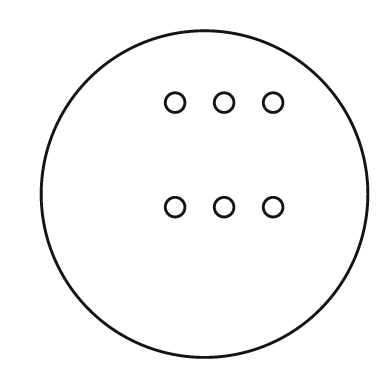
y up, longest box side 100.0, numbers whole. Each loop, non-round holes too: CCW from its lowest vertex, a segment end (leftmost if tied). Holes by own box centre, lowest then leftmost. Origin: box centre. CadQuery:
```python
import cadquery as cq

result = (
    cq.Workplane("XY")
    .moveTo(0.0, 0.0)
    .circle(50.0)
    .moveTo(-9.0, -4.0)
    .circle(3.0)
    .moveTo(6.0, -4.0)
    .circle(3.0)
    .moveTo(21.0, -4.0)
    .circle(3.0)
    .moveTo(-9.0, 28.0)
    .circle(3.0)
    .moveTo(6.0, 28.0)
    .circle(3.0)
    .moveTo(21.0, 28.0)
    .circle(3.0)
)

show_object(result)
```